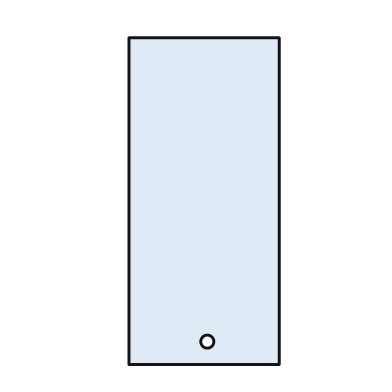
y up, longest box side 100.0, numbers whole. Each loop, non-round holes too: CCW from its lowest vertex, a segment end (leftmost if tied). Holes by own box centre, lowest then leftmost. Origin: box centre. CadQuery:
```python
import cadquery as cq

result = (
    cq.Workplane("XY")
    .moveTo(-23.0, -50.0)
    .lineTo(23.0, -50.0)
    .lineTo(23.0, 50.0)
    .lineTo(-23.0, 50.0)
    .close()
    .moveTo(1.0, -43.0)
    .circle(2.0)
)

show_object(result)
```